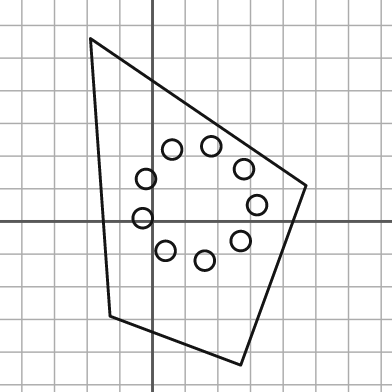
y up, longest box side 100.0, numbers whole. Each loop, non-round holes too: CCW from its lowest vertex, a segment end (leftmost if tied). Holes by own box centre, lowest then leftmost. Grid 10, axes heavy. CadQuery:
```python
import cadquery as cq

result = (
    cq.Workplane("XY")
    .moveTo(27.0, -44.0)
    .lineTo(47.0, 11.0)
    .lineTo(-19.0, 56.0)
    .lineTo(-13.0, -29.0)
    .close()
    .moveTo(16.0, -12.0)
    .circle(3.0)
    .moveTo(4.0, -9.0)
    .circle(3.0)
    .moveTo(27.0, -6.0)
    .circle(3.0)
    .moveTo(-3.0, 1.0)
    .circle(3.0)
    .moveTo(32.0, 5.0)
    .circle(3.0)
    .moveTo(-2.0, 13.0)
    .circle(3.0)
    .moveTo(28.0, 16.0)
    .circle(3.0)
    .moveTo(6.0, 22.0)
    .circle(3.0)
    .moveTo(18.0, 23.0)
    .circle(3.0)
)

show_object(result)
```